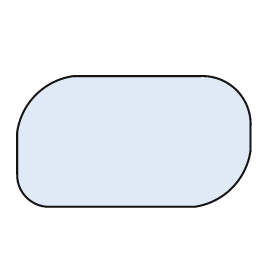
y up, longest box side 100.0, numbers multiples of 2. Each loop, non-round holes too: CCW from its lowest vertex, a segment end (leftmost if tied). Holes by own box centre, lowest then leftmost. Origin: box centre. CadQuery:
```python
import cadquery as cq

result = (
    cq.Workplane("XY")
    .moveTo(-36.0, -28.0)
    .lineTo(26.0, -28.0)
    .threePointArc((42.0, -20.0), (50.0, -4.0))
    .lineTo(50.0, 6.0)
    .threePointArc((44.0, 22.0), (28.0, 28.0))
    .lineTo(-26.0, 28.0)
    .threePointArc((-42.0, 20.0), (-50.0, 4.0))
    .lineTo(-50.0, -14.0)
    .threePointArc((-46.0, -24.0), (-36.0, -28.0))
    .close()
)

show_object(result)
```